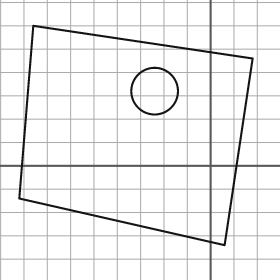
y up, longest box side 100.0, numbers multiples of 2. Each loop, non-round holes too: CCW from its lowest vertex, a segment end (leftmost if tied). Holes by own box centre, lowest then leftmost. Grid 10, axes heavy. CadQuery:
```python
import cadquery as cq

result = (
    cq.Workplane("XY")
    .moveTo(6.0, -34.0)
    .lineTo(18.0, 46.0)
    .lineTo(-76.0, 60.0)
    .lineTo(-82.0, -14.0)
    .close()
    .moveTo(-24.0, 32.0)
    .circle(10.0)
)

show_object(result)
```